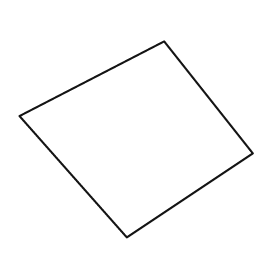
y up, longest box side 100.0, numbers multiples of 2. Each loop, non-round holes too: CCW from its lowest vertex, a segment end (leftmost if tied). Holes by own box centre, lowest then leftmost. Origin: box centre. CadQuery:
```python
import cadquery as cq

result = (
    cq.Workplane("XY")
    .moveTo(-4.0, -42.0)
    .lineTo(50.0, -6.0)
    .lineTo(12.0, 42.0)
    .lineTo(-50.0, 10.0)
    .close()
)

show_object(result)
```